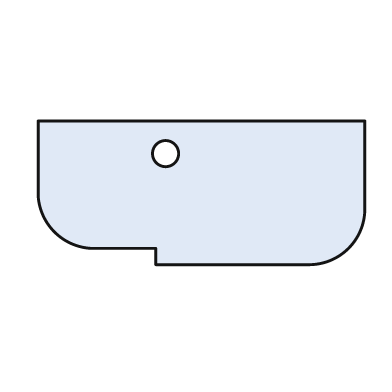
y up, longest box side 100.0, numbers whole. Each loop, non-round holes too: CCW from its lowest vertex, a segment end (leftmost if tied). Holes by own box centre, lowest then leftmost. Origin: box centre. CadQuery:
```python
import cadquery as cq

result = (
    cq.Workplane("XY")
    .moveTo(-14.0, -22.0)
    .lineTo(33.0, -22.0)
    .threePointArc((45.0, -17.0), (50.0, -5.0))
    .lineTo(50.0, 22.0)
    .lineTo(-50.0, 22.0)
    .lineTo(-50.0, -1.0)
    .threePointArc((-45.0, -12.0), (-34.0, -17.0))
    .lineTo(-14.0, -17.0)
    .close()
    .moveTo(-11.0, 12.0)
    .circle(4.0)
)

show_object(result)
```